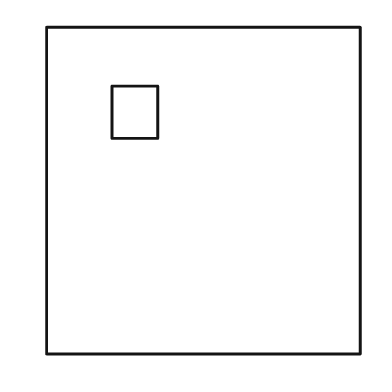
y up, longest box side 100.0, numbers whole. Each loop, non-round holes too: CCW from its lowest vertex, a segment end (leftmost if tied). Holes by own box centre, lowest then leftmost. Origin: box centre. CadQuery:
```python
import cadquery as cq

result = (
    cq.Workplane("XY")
    .moveTo(-48.0, -50.0)
    .lineTo(48.0, -50.0)
    .lineTo(48.0, 50.0)
    .lineTo(-48.0, 50.0)
    .close()
    .moveTo(-28.0, 16.0)
    .lineTo(-14.0, 16.0)
    .lineTo(-14.0, 32.0)
    .lineTo(-28.0, 32.0)
    .close()
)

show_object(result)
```